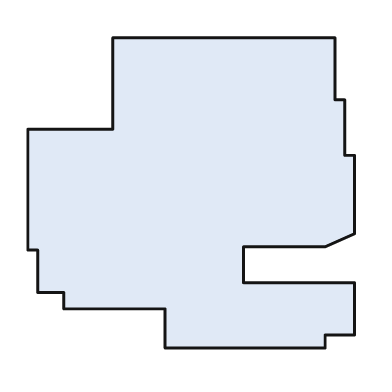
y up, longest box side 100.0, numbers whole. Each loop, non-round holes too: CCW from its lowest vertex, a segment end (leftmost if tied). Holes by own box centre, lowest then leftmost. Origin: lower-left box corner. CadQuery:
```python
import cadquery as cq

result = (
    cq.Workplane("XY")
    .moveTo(42.0, 0.0)
    .lineTo(91.0, 0.0)
    .lineTo(91.0, 4.0)
    .lineTo(100.0, 4.0)
    .lineTo(100.0, 20.0)
    .lineTo(66.0, 20.0)
    .lineTo(66.0, 31.0)
    .lineTo(91.0, 31.0)
    .lineTo(100.0, 35.0)
    .lineTo(100.0, 59.0)
    .lineTo(97.0, 59.0)
    .lineTo(97.0, 76.0)
    .lineTo(94.0, 76.0)
    .lineTo(94.0, 95.0)
    .lineTo(26.0, 95.0)
    .lineTo(26.0, 67.0)
    .lineTo(0.0, 67.0)
    .lineTo(0.0, 30.0)
    .lineTo(3.0, 30.0)
    .lineTo(3.0, 17.0)
    .lineTo(11.0, 17.0)
    .lineTo(11.0, 12.0)
    .lineTo(42.0, 12.0)
    .close()
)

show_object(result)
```